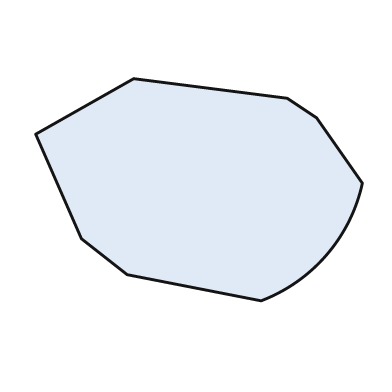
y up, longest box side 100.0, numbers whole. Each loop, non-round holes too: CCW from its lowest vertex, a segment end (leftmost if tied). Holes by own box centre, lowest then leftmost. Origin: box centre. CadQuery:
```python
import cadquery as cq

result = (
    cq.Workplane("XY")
    .moveTo(19.0, -34.0)
    .threePointArc((39.0, -20.0), (50.0, 2.0))
    .lineTo(36.0, 22.0)
    .lineTo(27.0, 28.0)
    .lineTo(-20.0, 34.0)
    .lineTo(-50.0, 17.0)
    .lineTo(-36.0, -15.0)
    .lineTo(-22.0, -26.0)
    .close()
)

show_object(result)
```